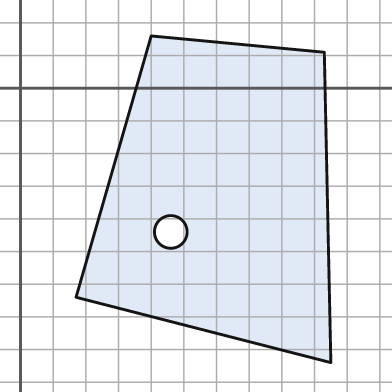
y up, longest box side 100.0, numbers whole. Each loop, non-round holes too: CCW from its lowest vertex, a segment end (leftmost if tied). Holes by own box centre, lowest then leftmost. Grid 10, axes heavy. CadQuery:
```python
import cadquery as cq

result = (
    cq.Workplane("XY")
    .moveTo(95.0, -84.0)
    .lineTo(93.0, 11.0)
    .lineTo(40.0, 16.0)
    .lineTo(17.0, -64.0)
    .close()
    .moveTo(46.0, -44.0)
    .circle(5.0)
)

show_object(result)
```